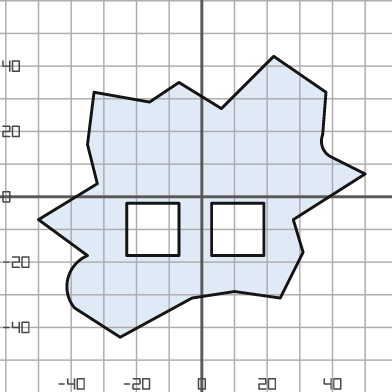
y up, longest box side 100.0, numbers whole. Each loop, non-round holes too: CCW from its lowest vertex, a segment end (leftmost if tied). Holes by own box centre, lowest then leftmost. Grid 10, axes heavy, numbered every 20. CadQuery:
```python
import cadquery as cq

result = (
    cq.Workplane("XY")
    .moveTo(-25.0, -43.0)
    .lineTo(-3.0, -31.0)
    .lineTo(10.0, -29.0)
    .lineTo(24.0, -31.0)
    .lineTo(31.0, -17.0)
    .lineTo(28.0, -7.0)
    .lineTo(50.0, 7.0)
    .lineTo(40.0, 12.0)
    .threePointArc((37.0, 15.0), (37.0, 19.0))
    .lineTo(38.0, 32.0)
    .lineTo(22.0, 43.0)
    .lineTo(6.0, 27.0)
    .lineTo(-7.0, 35.0)
    .lineTo(-16.0, 29.0)
    .lineTo(-33.0, 32.0)
    .lineTo(-35.0, 16.0)
    .lineTo(-32.0, 4.0)
    .lineTo(-50.0, -7.0)
    .lineTo(-35.0, -18.0)
    .threePointArc((-41.0, -25.0), (-39.0, -34.0))
    .close()
    .moveTo(-23.0, -18.0)
    .lineTo(-7.0, -18.0)
    .lineTo(-7.0, -2.0)
    .lineTo(-23.0, -2.0)
    .close()
    .moveTo(3.0, -18.0)
    .lineTo(19.0, -18.0)
    .lineTo(19.0, -2.0)
    .lineTo(3.0, -2.0)
    .close()
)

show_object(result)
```